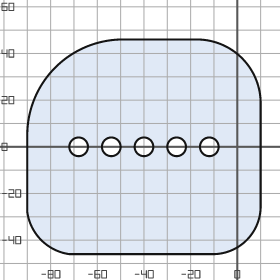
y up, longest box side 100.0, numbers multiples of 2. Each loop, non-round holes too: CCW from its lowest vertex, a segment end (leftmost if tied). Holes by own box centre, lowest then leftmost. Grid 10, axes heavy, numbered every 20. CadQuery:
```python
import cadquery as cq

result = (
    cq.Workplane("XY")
    .moveTo(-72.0, -46.0)
    .lineTo(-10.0, -46.0)
    .threePointArc((4.0, -40.0), (10.0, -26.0))
    .lineTo(10.0, 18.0)
    .threePointArc((2.0, 38.0), (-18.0, 46.0))
    .lineTo(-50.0, 46.0)
    .threePointArc((-78.0, 34.0), (-90.0, 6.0))
    .lineTo(-90.0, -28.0)
    .threePointArc((-84.0, -40.0), (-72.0, -46.0))
    .close()
    .moveTo(-68.0, 0.0)
    .circle(4.0)
    .moveTo(-54.0, 0.0)
    .circle(4.0)
    .moveTo(-40.0, 0.0)
    .circle(4.0)
    .moveTo(-26.0, 0.0)
    .circle(4.0)
    .moveTo(-12.0, 0.0)
    .circle(4.0)
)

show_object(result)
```